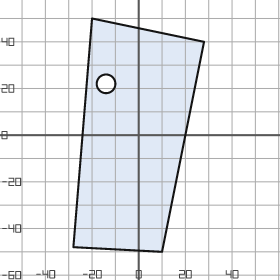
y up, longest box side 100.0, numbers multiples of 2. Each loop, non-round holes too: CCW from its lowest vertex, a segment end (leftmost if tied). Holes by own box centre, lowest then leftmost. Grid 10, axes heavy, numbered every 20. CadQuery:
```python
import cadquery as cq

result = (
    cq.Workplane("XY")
    .moveTo(10.0, -50.0)
    .lineTo(28.0, 40.0)
    .lineTo(-20.0, 50.0)
    .lineTo(-28.0, -48.0)
    .close()
    .moveTo(-14.0, 22.0)
    .circle(4.0)
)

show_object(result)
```